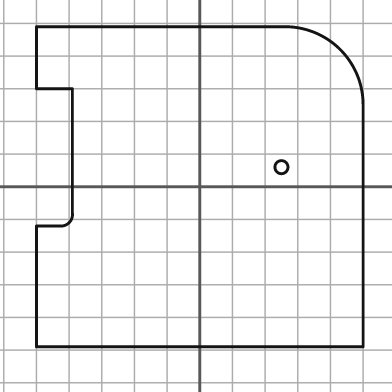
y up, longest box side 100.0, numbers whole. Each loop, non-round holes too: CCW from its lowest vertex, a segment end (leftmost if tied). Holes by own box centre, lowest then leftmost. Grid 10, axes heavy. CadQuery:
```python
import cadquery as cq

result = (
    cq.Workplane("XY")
    .moveTo(-50.0, -49.0)
    .lineTo(50.0, -49.0)
    .lineTo(50.0, 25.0)
    .threePointArc((43.0, 42.0), (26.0, 49.0))
    .lineTo(-50.0, 49.0)
    .lineTo(-50.0, 30.0)
    .lineTo(-39.0, 30.0)
    .lineTo(-39.0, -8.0)
    .threePointArc((-40.0, -11.0), (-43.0, -12.0))
    .lineTo(-50.0, -12.0)
    .close()
    .moveTo(25.0, 6.0)
    .circle(2.0)
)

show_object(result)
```